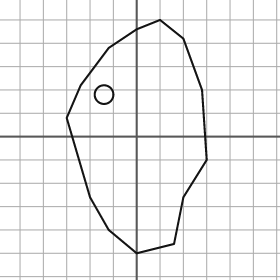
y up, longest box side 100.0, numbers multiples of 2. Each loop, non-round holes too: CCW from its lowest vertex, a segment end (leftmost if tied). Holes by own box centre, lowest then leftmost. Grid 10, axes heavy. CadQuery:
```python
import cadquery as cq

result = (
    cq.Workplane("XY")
    .moveTo(0.0, -50.0)
    .lineTo(16.0, -46.0)
    .lineTo(20.0, -26.0)
    .lineTo(30.0, -10.0)
    .lineTo(28.0, 20.0)
    .lineTo(20.0, 42.0)
    .lineTo(10.0, 50.0)
    .lineTo(0.0, 46.0)
    .lineTo(-12.0, 38.0)
    .lineTo(-24.0, 22.0)
    .lineTo(-30.0, 8.0)
    .lineTo(-20.0, -26.0)
    .lineTo(-12.0, -40.0)
    .close()
    .moveTo(-14.0, 18.0)
    .circle(4.0)
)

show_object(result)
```